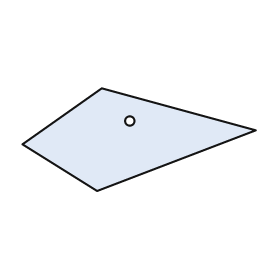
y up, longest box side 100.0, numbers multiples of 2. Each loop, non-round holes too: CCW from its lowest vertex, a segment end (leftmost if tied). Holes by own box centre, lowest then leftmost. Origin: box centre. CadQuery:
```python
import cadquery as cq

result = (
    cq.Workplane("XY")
    .moveTo(-18.0, -22.0)
    .lineTo(50.0, 4.0)
    .lineTo(-16.0, 22.0)
    .lineTo(-50.0, -2.0)
    .close()
    .moveTo(-4.0, 8.0)
    .circle(2.0)
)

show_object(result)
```